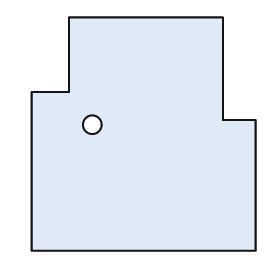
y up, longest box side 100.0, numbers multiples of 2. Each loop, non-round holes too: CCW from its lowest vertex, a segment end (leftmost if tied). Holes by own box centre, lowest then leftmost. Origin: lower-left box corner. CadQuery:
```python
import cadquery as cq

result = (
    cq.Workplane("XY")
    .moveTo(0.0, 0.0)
    .lineTo(96.0, 0.0)
    .lineTo(96.0, 56.0)
    .lineTo(82.0, 56.0)
    .lineTo(82.0, 100.0)
    .lineTo(16.0, 100.0)
    .lineTo(16.0, 68.0)
    .lineTo(0.0, 68.0)
    .close()
    .moveTo(26.0, 54.0)
    .circle(4.0)
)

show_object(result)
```